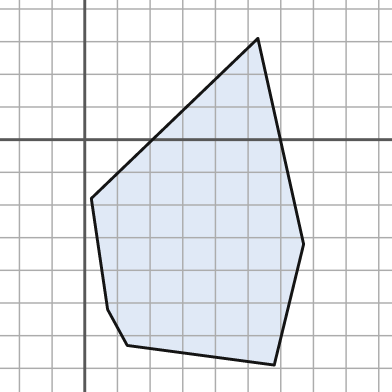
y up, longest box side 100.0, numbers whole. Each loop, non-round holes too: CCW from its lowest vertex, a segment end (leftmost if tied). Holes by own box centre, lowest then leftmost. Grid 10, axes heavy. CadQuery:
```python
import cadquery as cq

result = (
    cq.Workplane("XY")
    .moveTo(58.0, -69.0)
    .lineTo(67.0, -32.0)
    .lineTo(53.0, 31.0)
    .lineTo(2.0, -18.0)
    .lineTo(7.0, -52.0)
    .lineTo(13.0, -63.0)
    .close()
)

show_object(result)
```